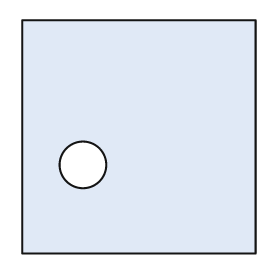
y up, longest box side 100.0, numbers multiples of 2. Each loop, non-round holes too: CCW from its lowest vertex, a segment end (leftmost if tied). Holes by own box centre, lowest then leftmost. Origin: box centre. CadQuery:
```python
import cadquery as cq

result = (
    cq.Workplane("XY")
    .moveTo(-50.0, -50.0)
    .lineTo(50.0, -50.0)
    .lineTo(50.0, 50.0)
    .lineTo(-50.0, 50.0)
    .close()
    .moveTo(-24.0, -12.0)
    .circle(10.0)
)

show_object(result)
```